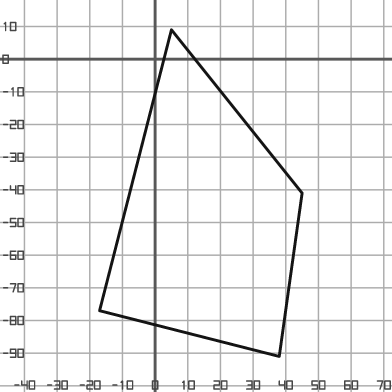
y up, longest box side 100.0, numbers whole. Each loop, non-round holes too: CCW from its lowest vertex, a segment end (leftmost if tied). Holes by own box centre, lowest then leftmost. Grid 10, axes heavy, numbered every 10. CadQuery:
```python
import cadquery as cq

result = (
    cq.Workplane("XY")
    .moveTo(38.0, -91.0)
    .lineTo(45.0, -41.0)
    .lineTo(5.0, 9.0)
    .lineTo(-17.0, -77.0)
    .close()
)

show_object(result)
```